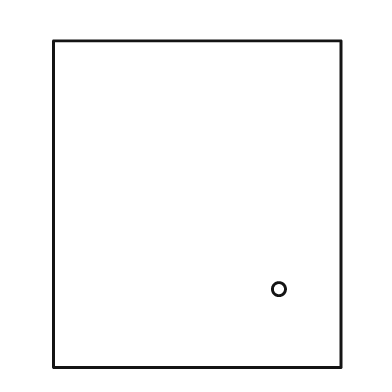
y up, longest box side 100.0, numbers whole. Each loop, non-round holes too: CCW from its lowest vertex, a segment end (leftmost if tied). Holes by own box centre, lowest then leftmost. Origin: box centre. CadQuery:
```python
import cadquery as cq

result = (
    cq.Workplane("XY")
    .moveTo(-44.0, -50.0)
    .lineTo(44.0, -50.0)
    .lineTo(44.0, 50.0)
    .lineTo(-44.0, 50.0)
    .close()
    .moveTo(25.0, -26.0)
    .circle(2.0)
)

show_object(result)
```